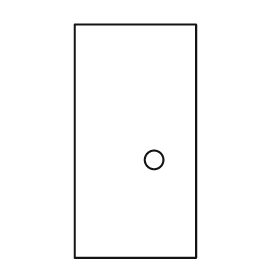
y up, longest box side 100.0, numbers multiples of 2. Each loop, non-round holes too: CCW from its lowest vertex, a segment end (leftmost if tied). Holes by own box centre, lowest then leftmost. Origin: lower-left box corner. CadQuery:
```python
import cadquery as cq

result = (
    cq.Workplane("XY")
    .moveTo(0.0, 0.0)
    .lineTo(52.0, 0.0)
    .lineTo(52.0, 100.0)
    .lineTo(0.0, 100.0)
    .close()
    .moveTo(34.0, 42.0)
    .circle(4.0)
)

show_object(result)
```